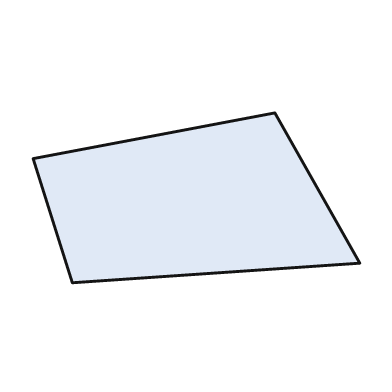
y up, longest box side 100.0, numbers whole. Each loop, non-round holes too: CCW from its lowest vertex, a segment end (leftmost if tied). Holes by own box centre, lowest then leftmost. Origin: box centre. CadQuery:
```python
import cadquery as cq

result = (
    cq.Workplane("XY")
    .moveTo(-38.0, -26.0)
    .lineTo(50.0, -20.0)
    .lineTo(24.0, 26.0)
    .lineTo(-50.0, 12.0)
    .close()
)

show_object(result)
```